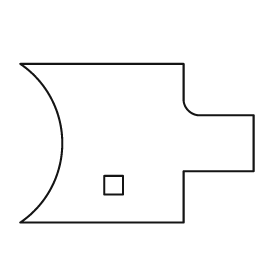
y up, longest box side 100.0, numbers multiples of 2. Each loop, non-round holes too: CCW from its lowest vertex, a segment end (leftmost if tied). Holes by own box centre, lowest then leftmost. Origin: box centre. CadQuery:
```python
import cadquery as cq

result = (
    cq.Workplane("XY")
    .moveTo(-50.0, -34.0)
    .lineTo(20.0, -34.0)
    .lineTo(20.0, -12.0)
    .lineTo(50.0, -12.0)
    .lineTo(50.0, 12.0)
    .lineTo(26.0, 12.0)
    .threePointArc((22.0, 14.0), (20.0, 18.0))
    .lineTo(20.0, 34.0)
    .lineTo(-50.0, 34.0)
    .threePointArc((-32.0, 0.0), (-50.0, -34.0))
    .close()
    .moveTo(-14.0, -22.0)
    .lineTo(-6.0, -22.0)
    .lineTo(-6.0, -14.0)
    .lineTo(-14.0, -14.0)
    .close()
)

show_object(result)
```